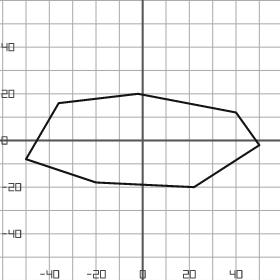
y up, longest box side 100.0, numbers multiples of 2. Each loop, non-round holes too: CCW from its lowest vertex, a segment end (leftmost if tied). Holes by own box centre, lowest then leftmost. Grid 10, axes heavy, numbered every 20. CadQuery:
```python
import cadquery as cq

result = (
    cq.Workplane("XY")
    .moveTo(22.0, -20.0)
    .lineTo(50.0, -2.0)
    .lineTo(40.0, 12.0)
    .lineTo(-2.0, 20.0)
    .lineTo(-36.0, 16.0)
    .lineTo(-50.0, -8.0)
    .lineTo(-20.0, -18.0)
    .close()
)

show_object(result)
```